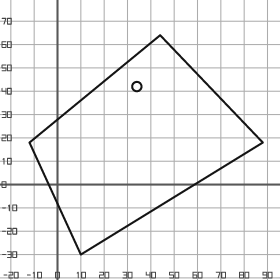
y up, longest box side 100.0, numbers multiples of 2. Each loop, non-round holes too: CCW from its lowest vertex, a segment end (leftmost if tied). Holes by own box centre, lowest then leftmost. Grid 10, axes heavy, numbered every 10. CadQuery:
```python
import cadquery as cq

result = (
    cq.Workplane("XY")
    .moveTo(10.0, -30.0)
    .lineTo(88.0, 18.0)
    .lineTo(44.0, 64.0)
    .lineTo(-12.0, 18.0)
    .close()
    .moveTo(34.0, 42.0)
    .circle(2.0)
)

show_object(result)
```